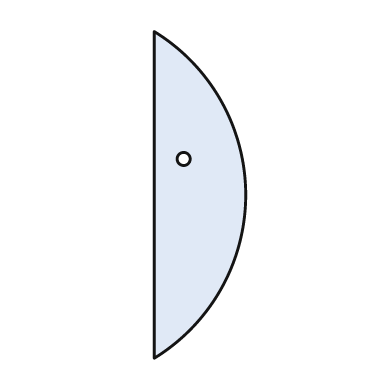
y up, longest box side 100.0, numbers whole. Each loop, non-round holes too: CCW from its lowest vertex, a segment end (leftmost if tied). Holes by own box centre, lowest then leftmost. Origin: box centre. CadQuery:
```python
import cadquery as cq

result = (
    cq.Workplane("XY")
    .moveTo(-14.0, -50.0)
    .threePointArc((14.0, 0.0), (-14.0, 50.0))
    .close()
    .moveTo(-5.0, 11.0)
    .circle(2.0)
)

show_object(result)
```